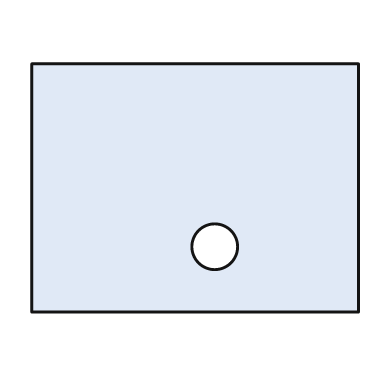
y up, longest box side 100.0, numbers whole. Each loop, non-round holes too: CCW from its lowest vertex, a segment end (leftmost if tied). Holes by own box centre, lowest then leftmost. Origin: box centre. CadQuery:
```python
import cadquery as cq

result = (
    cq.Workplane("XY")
    .moveTo(-50.0, -38.0)
    .lineTo(50.0, -38.0)
    .lineTo(50.0, 38.0)
    .lineTo(-50.0, 38.0)
    .close()
    .moveTo(6.0, -18.0)
    .circle(7.0)
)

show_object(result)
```